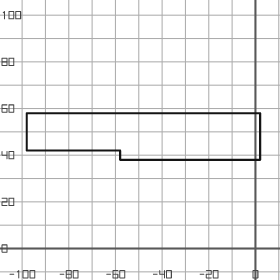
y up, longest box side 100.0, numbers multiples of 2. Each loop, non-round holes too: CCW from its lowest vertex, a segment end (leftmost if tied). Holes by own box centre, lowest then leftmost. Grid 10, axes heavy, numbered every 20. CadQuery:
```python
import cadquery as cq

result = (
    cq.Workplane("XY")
    .moveTo(-58.0, 38.0)
    .lineTo(2.0, 38.0)
    .lineTo(2.0, 58.0)
    .lineTo(-98.0, 58.0)
    .lineTo(-98.0, 42.0)
    .lineTo(-58.0, 42.0)
    .close()
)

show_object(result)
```